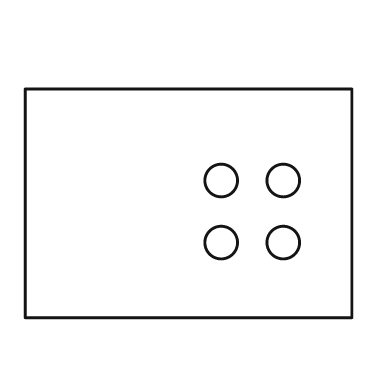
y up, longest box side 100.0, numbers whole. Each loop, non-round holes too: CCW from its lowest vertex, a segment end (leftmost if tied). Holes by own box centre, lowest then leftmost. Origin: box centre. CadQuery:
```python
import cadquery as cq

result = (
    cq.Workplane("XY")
    .moveTo(-50.0, -35.0)
    .lineTo(50.0, -35.0)
    .lineTo(50.0, 35.0)
    .lineTo(-50.0, 35.0)
    .close()
    .moveTo(10.0, -12.0)
    .circle(5.0)
    .moveTo(29.0, -12.0)
    .circle(5.0)
    .moveTo(10.0, 7.0)
    .circle(5.0)
    .moveTo(29.0, 7.0)
    .circle(5.0)
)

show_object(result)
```